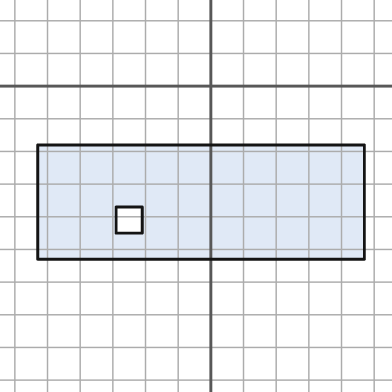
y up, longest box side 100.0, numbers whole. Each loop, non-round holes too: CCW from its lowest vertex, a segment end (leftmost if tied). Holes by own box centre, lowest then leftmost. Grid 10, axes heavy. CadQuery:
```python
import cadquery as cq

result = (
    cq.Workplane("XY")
    .moveTo(-53.0, -53.0)
    .lineTo(47.0, -53.0)
    .lineTo(47.0, -18.0)
    .lineTo(-53.0, -18.0)
    .close()
    .moveTo(-29.0, -45.0)
    .lineTo(-21.0, -45.0)
    .lineTo(-21.0, -37.0)
    .lineTo(-29.0, -37.0)
    .close()
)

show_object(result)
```